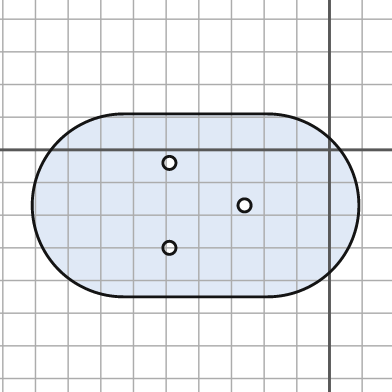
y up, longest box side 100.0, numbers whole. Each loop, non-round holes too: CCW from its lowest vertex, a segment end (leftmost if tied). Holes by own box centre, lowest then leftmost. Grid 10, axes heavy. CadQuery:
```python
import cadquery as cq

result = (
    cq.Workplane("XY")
    .moveTo(-63.0, -45.0)
    .lineTo(-19.0, -45.0)
    .threePointArc((9.0, -17.0), (-19.0, 11.0))
    .lineTo(-63.0, 11.0)
    .threePointArc((-91.0, -17.0), (-63.0, -45.0))
    .close()
    .moveTo(-49.0, -30.0)
    .circle(2.0)
    .moveTo(-26.0, -17.0)
    .circle(2.0)
    .moveTo(-49.0, -4.0)
    .circle(2.0)
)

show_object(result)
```